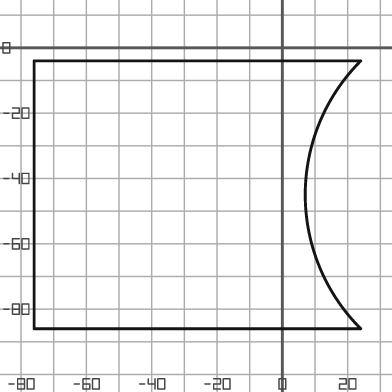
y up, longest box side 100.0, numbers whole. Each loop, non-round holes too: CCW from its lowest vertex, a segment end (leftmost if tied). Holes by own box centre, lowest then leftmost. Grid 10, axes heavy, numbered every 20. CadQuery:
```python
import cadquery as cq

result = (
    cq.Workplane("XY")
    .moveTo(-76.0, -86.0)
    .lineTo(24.0, -86.0)
    .threePointArc((7.0, -45.0), (24.0, -4.0))
    .lineTo(-76.0, -4.0)
    .close()
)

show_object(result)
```